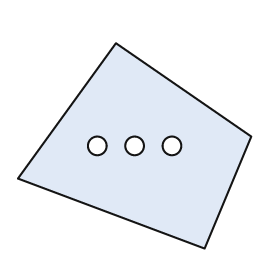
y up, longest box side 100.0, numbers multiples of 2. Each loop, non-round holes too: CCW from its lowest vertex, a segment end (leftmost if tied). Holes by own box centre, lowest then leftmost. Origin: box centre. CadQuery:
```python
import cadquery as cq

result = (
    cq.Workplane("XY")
    .moveTo(30.0, -44.0)
    .lineTo(50.0, 4.0)
    .lineTo(-8.0, 44.0)
    .lineTo(-50.0, -14.0)
    .close()
    .moveTo(-16.0, 0.0)
    .circle(4.0)
    .moveTo(0.0, 0.0)
    .circle(4.0)
    .moveTo(16.0, 0.0)
    .circle(4.0)
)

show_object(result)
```